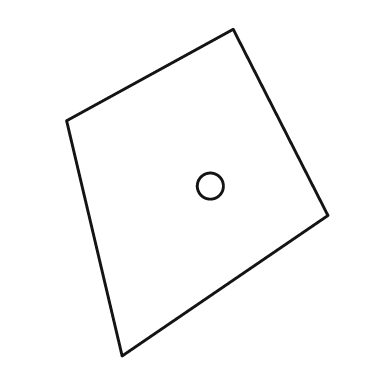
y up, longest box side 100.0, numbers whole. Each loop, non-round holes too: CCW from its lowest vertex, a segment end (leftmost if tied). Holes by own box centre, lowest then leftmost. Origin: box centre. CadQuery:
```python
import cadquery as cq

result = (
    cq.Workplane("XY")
    .moveTo(-23.0, -50.0)
    .lineTo(40.0, -7.0)
    .lineTo(11.0, 50.0)
    .lineTo(-40.0, 22.0)
    .close()
    .moveTo(4.0, 2.0)
    .circle(4.0)
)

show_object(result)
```